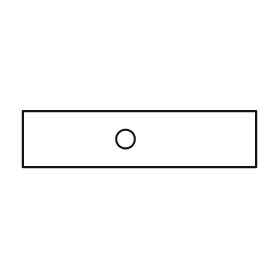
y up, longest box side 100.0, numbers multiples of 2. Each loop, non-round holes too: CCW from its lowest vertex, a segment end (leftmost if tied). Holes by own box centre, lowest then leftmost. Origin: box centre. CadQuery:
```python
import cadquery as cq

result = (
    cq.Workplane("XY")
    .moveTo(-50.0, -12.0)
    .lineTo(50.0, -12.0)
    .lineTo(50.0, 12.0)
    .lineTo(-50.0, 12.0)
    .close()
    .moveTo(-6.0, 0.0)
    .circle(4.0)
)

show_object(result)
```